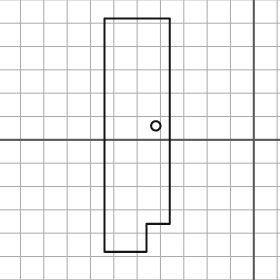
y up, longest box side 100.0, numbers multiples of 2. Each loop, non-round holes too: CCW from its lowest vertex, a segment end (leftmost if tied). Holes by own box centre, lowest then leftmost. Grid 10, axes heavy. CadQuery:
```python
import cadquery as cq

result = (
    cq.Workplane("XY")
    .moveTo(-64.0, -48.0)
    .lineTo(-46.0, -48.0)
    .lineTo(-46.0, -36.0)
    .lineTo(-36.0, -36.0)
    .lineTo(-36.0, 52.0)
    .lineTo(-64.0, 52.0)
    .close()
    .moveTo(-42.0, 6.0)
    .circle(2.0)
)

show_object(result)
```